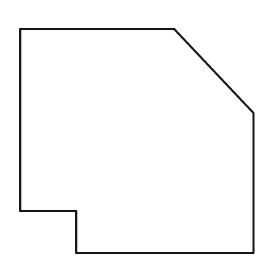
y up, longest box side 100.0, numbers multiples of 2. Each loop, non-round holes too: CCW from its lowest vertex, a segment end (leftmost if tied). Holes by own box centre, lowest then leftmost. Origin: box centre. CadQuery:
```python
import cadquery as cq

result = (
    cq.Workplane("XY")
    .moveTo(-26.0, -48.0)
    .lineTo(50.0, -48.0)
    .lineTo(50.0, 12.0)
    .lineTo(16.0, 48.0)
    .lineTo(-50.0, 48.0)
    .lineTo(-50.0, -30.0)
    .lineTo(-26.0, -30.0)
    .close()
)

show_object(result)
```